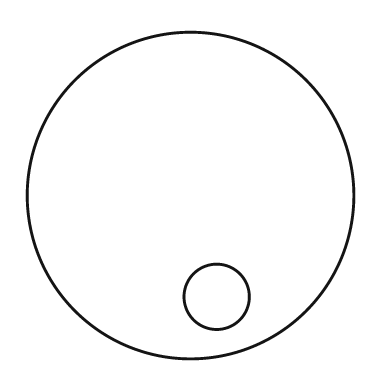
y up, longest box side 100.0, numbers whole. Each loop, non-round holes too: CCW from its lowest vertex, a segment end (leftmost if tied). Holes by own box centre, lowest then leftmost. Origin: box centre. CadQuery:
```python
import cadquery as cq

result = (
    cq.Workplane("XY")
    .moveTo(0.0, 0.0)
    .circle(50.0)
    .moveTo(8.0, -31.0)
    .circle(10.0)
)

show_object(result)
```